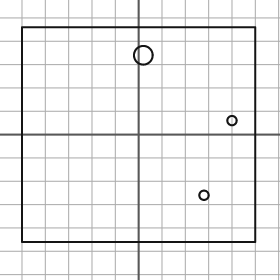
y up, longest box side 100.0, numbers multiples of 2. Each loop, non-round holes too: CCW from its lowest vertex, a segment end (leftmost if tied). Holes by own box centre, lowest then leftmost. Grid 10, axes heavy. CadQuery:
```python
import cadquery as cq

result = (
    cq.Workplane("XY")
    .moveTo(-50.0, -46.0)
    .lineTo(50.0, -46.0)
    .lineTo(50.0, 46.0)
    .lineTo(-50.0, 46.0)
    .close()
    .moveTo(28.0, -26.0)
    .circle(2.0)
    .moveTo(40.0, 6.0)
    .circle(2.0)
    .moveTo(2.0, 34.0)
    .circle(4.0)
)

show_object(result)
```